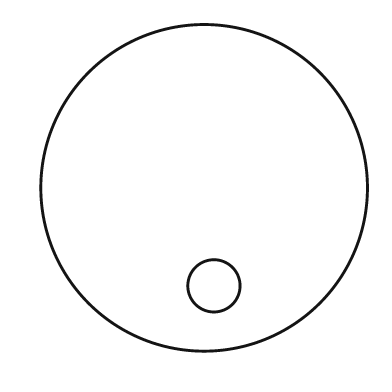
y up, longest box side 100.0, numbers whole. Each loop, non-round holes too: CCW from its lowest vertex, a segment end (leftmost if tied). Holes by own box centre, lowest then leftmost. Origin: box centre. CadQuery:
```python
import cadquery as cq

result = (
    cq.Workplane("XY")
    .moveTo(0.0, 0.0)
    .circle(50.0)
    .moveTo(3.0, -30.0)
    .circle(8.0)
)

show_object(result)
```